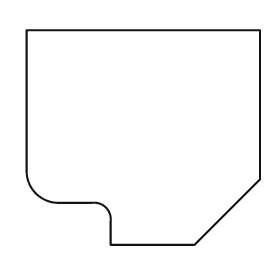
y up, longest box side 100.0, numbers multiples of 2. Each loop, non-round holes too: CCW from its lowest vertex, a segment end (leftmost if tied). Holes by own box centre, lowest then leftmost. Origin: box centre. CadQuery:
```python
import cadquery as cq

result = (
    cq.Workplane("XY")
    .moveTo(-14.0, -46.0)
    .lineTo(22.0, -46.0)
    .lineTo(50.0, -18.0)
    .lineTo(50.0, 46.0)
    .lineTo(-50.0, 46.0)
    .lineTo(-50.0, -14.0)
    .threePointArc((-46.0, -24.0), (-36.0, -28.0))
    .lineTo(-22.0, -28.0)
    .threePointArc((-16.0, -30.0), (-14.0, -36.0))
    .close()
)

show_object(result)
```